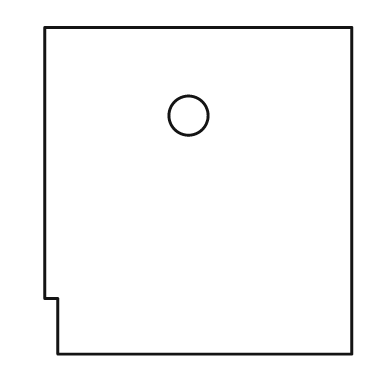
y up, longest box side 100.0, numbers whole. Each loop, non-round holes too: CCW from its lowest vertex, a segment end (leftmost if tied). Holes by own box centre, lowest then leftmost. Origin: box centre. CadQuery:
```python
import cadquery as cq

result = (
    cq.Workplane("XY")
    .moveTo(-43.0, -50.0)
    .lineTo(47.0, -50.0)
    .lineTo(47.0, 50.0)
    .lineTo(-47.0, 50.0)
    .lineTo(-47.0, -33.0)
    .lineTo(-43.0, -33.0)
    .close()
    .moveTo(-3.0, 23.0)
    .circle(6.0)
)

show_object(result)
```